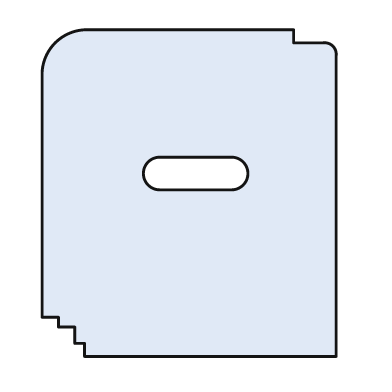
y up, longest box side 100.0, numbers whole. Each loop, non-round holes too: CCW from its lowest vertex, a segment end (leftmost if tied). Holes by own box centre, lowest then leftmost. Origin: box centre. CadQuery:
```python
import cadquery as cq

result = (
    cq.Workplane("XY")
    .moveTo(-32.0, -50.0)
    .lineTo(45.0, -50.0)
    .lineTo(45.0, 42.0)
    .threePointArc((44.0, 45.0), (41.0, 46.0))
    .lineTo(32.0, 46.0)
    .lineTo(32.0, 50.0)
    .lineTo(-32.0, 50.0)
    .threePointArc((-41.0, 46.0), (-45.0, 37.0))
    .lineTo(-45.0, -38.0)
    .lineTo(-40.0, -38.0)
    .lineTo(-40.0, -41.0)
    .lineTo(-35.0, -41.0)
    .lineTo(-35.0, -46.0)
    .lineTo(-32.0, -46.0)
    .close()
    .moveTo(-9.0, 1.0)
    .lineTo(13.0, 1.0)
    .threePointArc((18.0, 6.0), (13.0, 11.0))
    .lineTo(-9.0, 11.0)
    .threePointArc((-14.0, 6.0), (-9.0, 1.0))
    .close()
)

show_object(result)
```